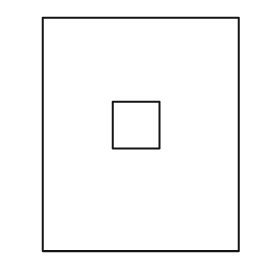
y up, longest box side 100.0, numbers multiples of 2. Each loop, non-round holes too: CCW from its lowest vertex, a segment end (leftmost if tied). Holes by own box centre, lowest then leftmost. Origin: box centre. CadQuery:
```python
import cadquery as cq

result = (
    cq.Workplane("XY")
    .moveTo(-42.0, -50.0)
    .lineTo(42.0, -50.0)
    .lineTo(42.0, 50.0)
    .lineTo(-42.0, 50.0)
    .close()
    .moveTo(-12.0, -6.0)
    .lineTo(8.0, -6.0)
    .lineTo(8.0, 14.0)
    .lineTo(-12.0, 14.0)
    .close()
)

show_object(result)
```